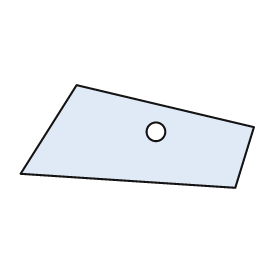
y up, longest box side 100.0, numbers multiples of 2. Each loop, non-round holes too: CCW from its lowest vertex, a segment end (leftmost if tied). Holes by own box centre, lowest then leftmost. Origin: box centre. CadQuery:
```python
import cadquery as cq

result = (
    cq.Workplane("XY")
    .moveTo(42.0, -22.0)
    .lineTo(50.0, 4.0)
    .lineTo(-26.0, 22.0)
    .lineTo(-50.0, -16.0)
    .close()
    .moveTo(8.0, 2.0)
    .circle(4.0)
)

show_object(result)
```